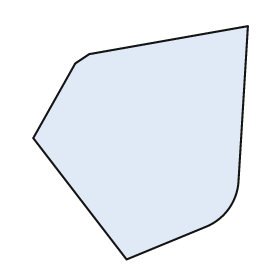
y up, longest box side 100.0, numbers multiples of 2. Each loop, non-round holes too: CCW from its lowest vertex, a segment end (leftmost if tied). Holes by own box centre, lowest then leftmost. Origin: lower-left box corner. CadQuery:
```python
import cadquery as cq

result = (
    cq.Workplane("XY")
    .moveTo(40.0, 0.0)
    .lineTo(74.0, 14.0)
    .threePointArc((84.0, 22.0), (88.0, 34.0))
    .lineTo(92.0, 100.0)
    .lineTo(24.0, 88.0)
    .lineTo(18.0, 84.0)
    .lineTo(0.0, 52.0)
    .close()
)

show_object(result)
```